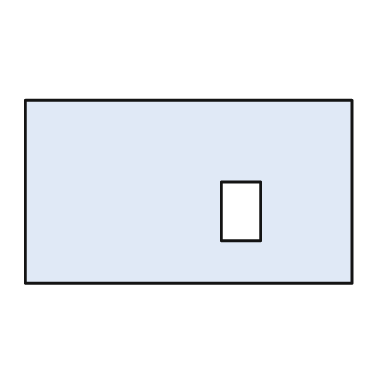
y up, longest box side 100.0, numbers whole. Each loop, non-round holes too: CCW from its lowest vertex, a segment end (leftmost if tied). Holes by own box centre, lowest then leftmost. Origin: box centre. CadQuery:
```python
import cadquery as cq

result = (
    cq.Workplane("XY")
    .moveTo(-50.0, -28.0)
    .lineTo(50.0, -28.0)
    .lineTo(50.0, 28.0)
    .lineTo(-50.0, 28.0)
    .close()
    .moveTo(10.0, -15.0)
    .lineTo(22.0, -15.0)
    .lineTo(22.0, 3.0)
    .lineTo(10.0, 3.0)
    .close()
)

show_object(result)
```